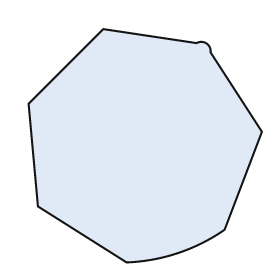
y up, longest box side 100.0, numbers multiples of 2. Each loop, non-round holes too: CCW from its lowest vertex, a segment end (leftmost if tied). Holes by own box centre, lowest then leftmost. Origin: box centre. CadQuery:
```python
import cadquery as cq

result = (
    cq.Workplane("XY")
    .moveTo(-8.0, -50.0)
    .threePointArc((14.0, -46.0), (34.0, -36.0))
    .lineTo(50.0, 6.0)
    .lineTo(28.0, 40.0)
    .threePointArc((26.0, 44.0), (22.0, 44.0))
    .lineTo(-18.0, 50.0)
    .lineTo(-50.0, 18.0)
    .lineTo(-46.0, -26.0)
    .close()
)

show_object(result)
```